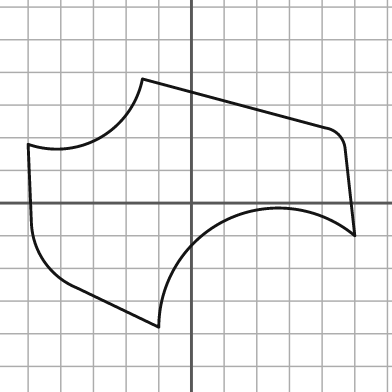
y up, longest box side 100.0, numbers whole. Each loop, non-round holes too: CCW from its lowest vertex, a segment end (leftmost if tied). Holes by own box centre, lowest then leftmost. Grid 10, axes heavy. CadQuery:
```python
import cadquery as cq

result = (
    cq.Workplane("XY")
    .moveTo(-10.0, -38.0)
    .threePointArc((11.0, -5.0), (50.0, -10.0))
    .lineTo(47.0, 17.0)
    .threePointArc((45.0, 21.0), (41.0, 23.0))
    .lineTo(-15.0, 38.0)
    .threePointArc((-28.0, 20.0), (-50.0, 18.0))
    .lineTo(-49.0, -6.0)
    .threePointArc((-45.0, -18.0), (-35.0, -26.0))
    .close()
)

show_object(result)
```